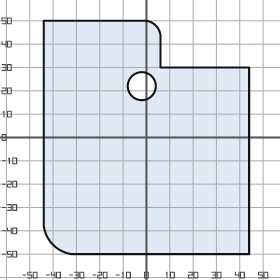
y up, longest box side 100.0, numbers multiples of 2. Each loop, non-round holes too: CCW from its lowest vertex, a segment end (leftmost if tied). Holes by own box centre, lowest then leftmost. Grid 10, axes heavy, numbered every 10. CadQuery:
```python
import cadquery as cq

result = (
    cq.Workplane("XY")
    .moveTo(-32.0, -50.0)
    .lineTo(44.0, -50.0)
    .lineTo(44.0, 30.0)
    .lineTo(6.0, 30.0)
    .lineTo(6.0, 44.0)
    .threePointArc((4.0, 48.0), (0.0, 50.0))
    .lineTo(-44.0, 50.0)
    .lineTo(-44.0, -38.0)
    .threePointArc((-40.0, -46.0), (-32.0, -50.0))
    .close()
    .moveTo(-2.0, 22.0)
    .circle(6.0)
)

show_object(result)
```